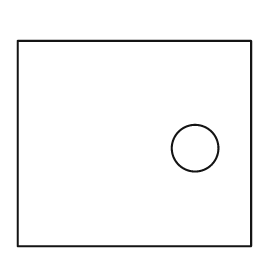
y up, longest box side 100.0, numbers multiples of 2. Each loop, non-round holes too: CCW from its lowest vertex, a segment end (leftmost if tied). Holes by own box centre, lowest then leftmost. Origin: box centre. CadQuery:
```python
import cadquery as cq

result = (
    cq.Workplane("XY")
    .moveTo(-50.0, -44.0)
    .lineTo(50.0, -44.0)
    .lineTo(50.0, 44.0)
    .lineTo(-50.0, 44.0)
    .close()
    .moveTo(26.0, -2.0)
    .circle(10.0)
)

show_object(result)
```